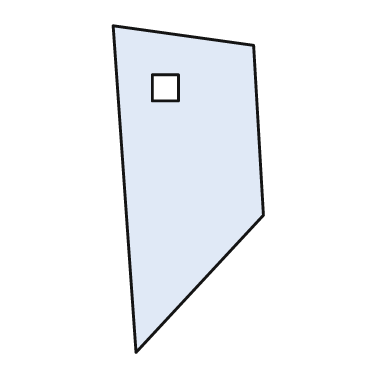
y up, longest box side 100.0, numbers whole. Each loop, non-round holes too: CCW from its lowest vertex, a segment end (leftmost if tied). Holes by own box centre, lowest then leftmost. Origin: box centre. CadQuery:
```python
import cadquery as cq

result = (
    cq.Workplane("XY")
    .moveTo(-16.0, -50.0)
    .lineTo(23.0, -8.0)
    .lineTo(20.0, 44.0)
    .lineTo(-23.0, 50.0)
    .close()
    .moveTo(-11.0, 27.0)
    .lineTo(-3.0, 27.0)
    .lineTo(-3.0, 35.0)
    .lineTo(-11.0, 35.0)
    .close()
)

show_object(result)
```